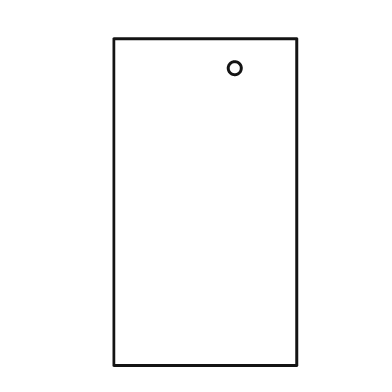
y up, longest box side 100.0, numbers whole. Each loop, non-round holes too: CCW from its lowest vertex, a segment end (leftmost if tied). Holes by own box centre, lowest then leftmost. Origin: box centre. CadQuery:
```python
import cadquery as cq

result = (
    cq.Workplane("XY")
    .moveTo(-28.0, -50.0)
    .lineTo(28.0, -50.0)
    .lineTo(28.0, 50.0)
    .lineTo(-28.0, 50.0)
    .close()
    .moveTo(9.0, 41.0)
    .circle(2.0)
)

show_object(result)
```